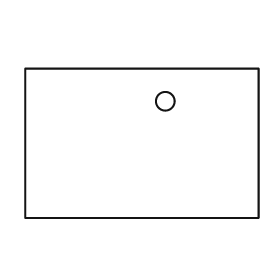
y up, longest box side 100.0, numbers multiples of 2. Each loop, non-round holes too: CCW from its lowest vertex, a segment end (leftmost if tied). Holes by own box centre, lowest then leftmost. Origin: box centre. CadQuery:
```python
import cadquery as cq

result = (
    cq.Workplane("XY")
    .moveTo(-50.0, -32.0)
    .lineTo(50.0, -32.0)
    .lineTo(50.0, 32.0)
    .lineTo(-50.0, 32.0)
    .close()
    .moveTo(10.0, 18.0)
    .circle(4.0)
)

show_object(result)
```